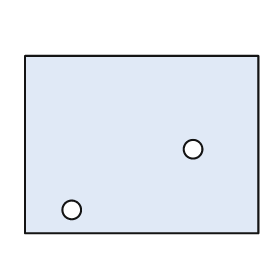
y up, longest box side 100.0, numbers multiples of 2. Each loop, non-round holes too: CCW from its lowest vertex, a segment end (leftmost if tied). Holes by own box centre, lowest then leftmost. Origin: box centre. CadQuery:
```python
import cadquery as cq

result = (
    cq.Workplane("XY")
    .moveTo(-50.0, -38.0)
    .lineTo(50.0, -38.0)
    .lineTo(50.0, 38.0)
    .lineTo(-50.0, 38.0)
    .close()
    .moveTo(-30.0, -28.0)
    .circle(4.0)
    .moveTo(22.0, -2.0)
    .circle(4.0)
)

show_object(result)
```